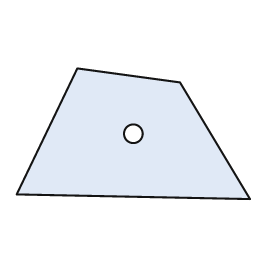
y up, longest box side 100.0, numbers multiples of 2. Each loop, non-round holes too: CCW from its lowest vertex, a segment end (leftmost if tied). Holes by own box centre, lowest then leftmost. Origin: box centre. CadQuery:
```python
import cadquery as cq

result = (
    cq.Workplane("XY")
    .moveTo(50.0, -28.0)
    .lineTo(20.0, 22.0)
    .lineTo(-24.0, 28.0)
    .lineTo(-50.0, -26.0)
    .close()
    .moveTo(0.0, 0.0)
    .circle(4.0)
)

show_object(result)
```